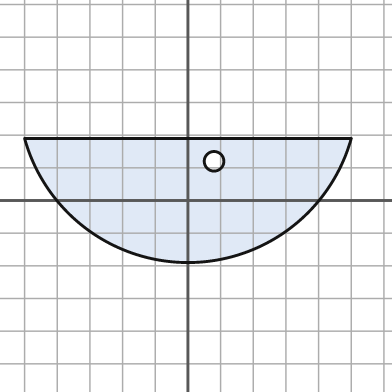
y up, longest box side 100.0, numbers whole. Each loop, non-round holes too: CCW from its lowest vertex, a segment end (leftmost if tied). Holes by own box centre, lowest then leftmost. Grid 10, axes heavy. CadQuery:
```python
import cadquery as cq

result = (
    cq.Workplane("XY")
    .moveTo(-50.0, 19.0)
    .threePointArc((0.0, -19.0), (50.0, 19.0))
    .close()
    .moveTo(8.0, 12.0)
    .circle(3.0)
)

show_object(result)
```